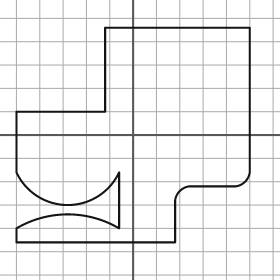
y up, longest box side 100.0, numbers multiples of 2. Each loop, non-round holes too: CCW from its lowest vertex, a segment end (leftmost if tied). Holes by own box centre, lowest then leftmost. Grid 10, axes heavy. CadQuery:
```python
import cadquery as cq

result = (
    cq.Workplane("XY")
    .moveTo(-50.0, -46.0)
    .lineTo(18.0, -46.0)
    .lineTo(18.0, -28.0)
    .threePointArc((20.0, -24.0), (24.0, -22.0))
    .lineTo(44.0, -22.0)
    .threePointArc((48.0, -20.0), (50.0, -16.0))
    .lineTo(50.0, 46.0)
    .lineTo(-12.0, 46.0)
    .lineTo(-12.0, 10.0)
    .lineTo(-50.0, 10.0)
    .lineTo(-50.0, -16.0)
    .threePointArc((-28.0, -30.0), (-6.0, -16.0))
    .lineTo(-6.0, -40.0)
    .threePointArc((-28.0, -34.0), (-50.0, -40.0))
    .close()
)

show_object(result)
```